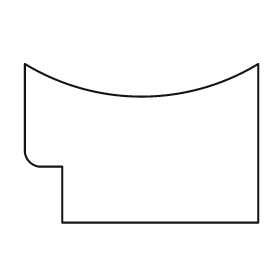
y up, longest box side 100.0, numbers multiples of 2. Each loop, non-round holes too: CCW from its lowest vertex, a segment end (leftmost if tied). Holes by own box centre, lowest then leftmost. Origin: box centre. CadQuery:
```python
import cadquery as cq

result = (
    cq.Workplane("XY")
    .moveTo(-34.0, -34.0)
    .lineTo(50.0, -34.0)
    .lineTo(50.0, 34.0)
    .threePointArc((0.0, 20.0), (-50.0, 34.0))
    .lineTo(-50.0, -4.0)
    .threePointArc((-48.0, -8.0), (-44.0, -10.0))
    .lineTo(-34.0, -10.0)
    .close()
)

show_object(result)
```